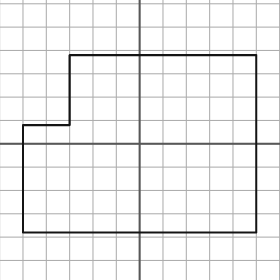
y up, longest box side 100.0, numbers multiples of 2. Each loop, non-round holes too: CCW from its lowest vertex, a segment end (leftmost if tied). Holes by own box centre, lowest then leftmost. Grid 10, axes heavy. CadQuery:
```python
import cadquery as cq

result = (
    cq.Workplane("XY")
    .moveTo(-50.0, -38.0)
    .lineTo(50.0, -38.0)
    .lineTo(50.0, 38.0)
    .lineTo(-30.0, 38.0)
    .lineTo(-30.0, 8.0)
    .lineTo(-50.0, 8.0)
    .close()
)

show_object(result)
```